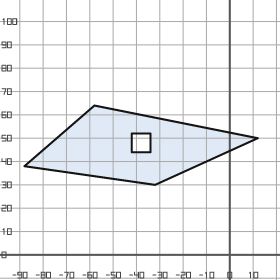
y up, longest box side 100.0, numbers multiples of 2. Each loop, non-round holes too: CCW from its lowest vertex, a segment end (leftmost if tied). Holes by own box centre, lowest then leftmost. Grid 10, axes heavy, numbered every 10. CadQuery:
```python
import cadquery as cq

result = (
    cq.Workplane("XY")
    .moveTo(-32.0, 30.0)
    .lineTo(12.0, 50.0)
    .lineTo(-58.0, 64.0)
    .lineTo(-88.0, 38.0)
    .close()
    .moveTo(-42.0, 44.0)
    .lineTo(-34.0, 44.0)
    .lineTo(-34.0, 52.0)
    .lineTo(-42.0, 52.0)
    .close()
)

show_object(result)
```